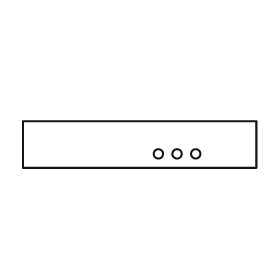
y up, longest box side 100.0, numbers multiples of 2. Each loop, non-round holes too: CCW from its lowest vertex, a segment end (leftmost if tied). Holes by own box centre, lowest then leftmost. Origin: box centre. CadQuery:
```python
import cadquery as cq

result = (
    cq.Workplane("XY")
    .moveTo(-50.0, -10.0)
    .lineTo(50.0, -10.0)
    .lineTo(50.0, 10.0)
    .lineTo(-50.0, 10.0)
    .close()
    .moveTo(8.0, -4.0)
    .circle(2.0)
    .moveTo(16.0, -4.0)
    .circle(2.0)
    .moveTo(24.0, -4.0)
    .circle(2.0)
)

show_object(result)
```